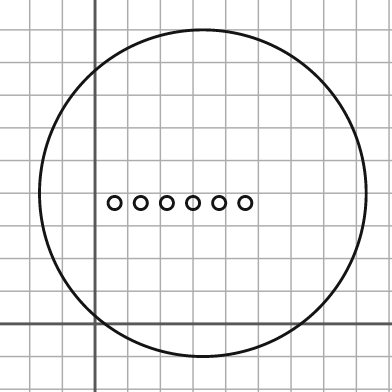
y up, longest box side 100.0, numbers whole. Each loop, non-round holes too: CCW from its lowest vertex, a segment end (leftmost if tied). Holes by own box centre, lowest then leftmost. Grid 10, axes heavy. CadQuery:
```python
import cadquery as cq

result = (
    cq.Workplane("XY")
    .moveTo(33.0, 40.0)
    .circle(50.0)
    .moveTo(6.0, 37.0)
    .circle(2.0)
    .moveTo(14.0, 37.0)
    .circle(2.0)
    .moveTo(22.0, 37.0)
    .circle(2.0)
    .moveTo(30.0, 37.0)
    .circle(2.0)
    .moveTo(38.0, 37.0)
    .circle(2.0)
    .moveTo(46.0, 37.0)
    .circle(2.0)
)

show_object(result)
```